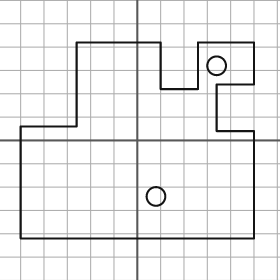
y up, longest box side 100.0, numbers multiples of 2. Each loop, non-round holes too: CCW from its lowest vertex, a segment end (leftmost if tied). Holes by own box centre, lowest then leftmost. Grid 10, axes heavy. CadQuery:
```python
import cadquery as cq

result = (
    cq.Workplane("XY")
    .moveTo(-50.0, -42.0)
    .lineTo(50.0, -42.0)
    .lineTo(50.0, 4.0)
    .lineTo(34.0, 4.0)
    .lineTo(34.0, 24.0)
    .lineTo(50.0, 24.0)
    .lineTo(50.0, 42.0)
    .lineTo(26.0, 42.0)
    .lineTo(26.0, 22.0)
    .lineTo(10.0, 22.0)
    .lineTo(10.0, 42.0)
    .lineTo(-26.0, 42.0)
    .lineTo(-26.0, 6.0)
    .lineTo(-50.0, 6.0)
    .close()
    .moveTo(8.0, -24.0)
    .circle(4.0)
    .moveTo(34.0, 32.0)
    .circle(4.0)
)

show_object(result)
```